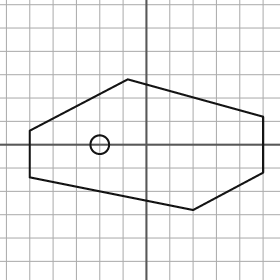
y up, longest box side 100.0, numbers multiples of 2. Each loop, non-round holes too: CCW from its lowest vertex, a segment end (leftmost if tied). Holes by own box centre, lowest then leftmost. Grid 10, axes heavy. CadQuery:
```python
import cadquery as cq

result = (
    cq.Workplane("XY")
    .moveTo(20.0, -28.0)
    .lineTo(50.0, -12.0)
    .lineTo(50.0, 12.0)
    .lineTo(-8.0, 28.0)
    .lineTo(-50.0, 6.0)
    .lineTo(-50.0, -14.0)
    .close()
    .moveTo(-20.0, 0.0)
    .circle(4.0)
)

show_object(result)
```